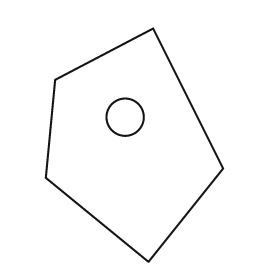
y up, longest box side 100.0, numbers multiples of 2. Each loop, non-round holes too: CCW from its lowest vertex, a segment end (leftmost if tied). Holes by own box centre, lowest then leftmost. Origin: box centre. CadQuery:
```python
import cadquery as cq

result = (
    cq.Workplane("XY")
    .moveTo(6.0, -50.0)
    .lineTo(38.0, -10.0)
    .lineTo(8.0, 50.0)
    .lineTo(-34.0, 28.0)
    .lineTo(-38.0, -14.0)
    .close()
    .moveTo(-4.0, 12.0)
    .circle(8.0)
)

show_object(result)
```